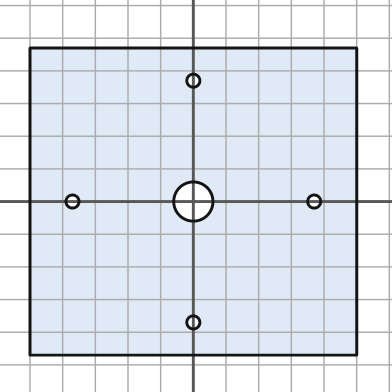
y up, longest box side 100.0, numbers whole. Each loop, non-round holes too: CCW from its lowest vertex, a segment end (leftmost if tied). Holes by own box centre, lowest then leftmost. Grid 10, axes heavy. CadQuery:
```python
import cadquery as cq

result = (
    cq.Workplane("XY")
    .moveTo(-50.0, -47.0)
    .lineTo(50.0, -47.0)
    .lineTo(50.0, 47.0)
    .lineTo(-50.0, 47.0)
    .close()
    .moveTo(0.0, -37.0)
    .circle(2.0)
    .moveTo(-37.0, 0.0)
    .circle(2.0)
    .moveTo(0.0, 0.0)
    .circle(6.0)
    .moveTo(37.0, 0.0)
    .circle(2.0)
    .moveTo(0.0, 37.0)
    .circle(2.0)
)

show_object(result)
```